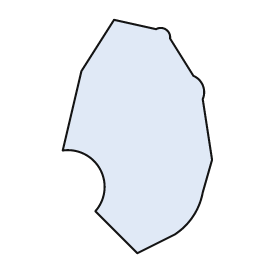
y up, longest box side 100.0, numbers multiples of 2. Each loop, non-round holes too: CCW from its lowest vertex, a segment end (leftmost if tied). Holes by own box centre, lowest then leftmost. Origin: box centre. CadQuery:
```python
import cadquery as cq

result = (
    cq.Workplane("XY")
    .moveTo(0.0, -50.0)
    .lineTo(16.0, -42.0)
    .threePointArc((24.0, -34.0), (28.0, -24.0))
    .lineTo(32.0, -10.0)
    .lineTo(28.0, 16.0)
    .threePointArc((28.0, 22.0), (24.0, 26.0))
    .lineTo(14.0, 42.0)
    .threePointArc((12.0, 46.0), (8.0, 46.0))
    .lineTo(-10.0, 50.0)
    .lineTo(-24.0, 28.0)
    .lineTo(-32.0, -6.0)
    .threePointArc((-16.0, -14.0), (-18.0, -32.0))
    .close()
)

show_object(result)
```